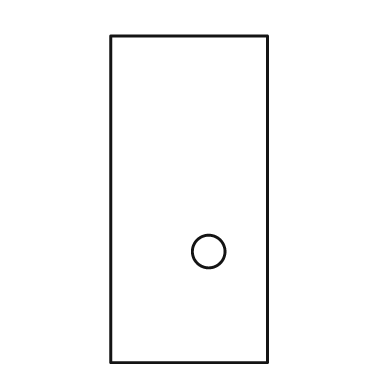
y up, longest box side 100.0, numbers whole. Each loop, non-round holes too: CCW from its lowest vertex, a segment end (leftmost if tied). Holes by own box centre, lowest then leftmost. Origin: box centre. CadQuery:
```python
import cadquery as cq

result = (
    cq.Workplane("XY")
    .moveTo(-24.0, -50.0)
    .lineTo(24.0, -50.0)
    .lineTo(24.0, 50.0)
    .lineTo(-24.0, 50.0)
    .close()
    .moveTo(6.0, -16.0)
    .circle(5.0)
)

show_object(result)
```